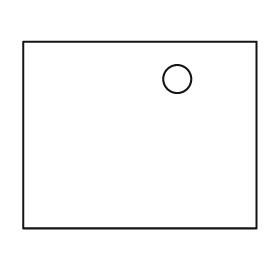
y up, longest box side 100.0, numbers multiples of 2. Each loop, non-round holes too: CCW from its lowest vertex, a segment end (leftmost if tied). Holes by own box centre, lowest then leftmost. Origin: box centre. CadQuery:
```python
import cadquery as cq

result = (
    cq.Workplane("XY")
    .moveTo(-50.0, -40.0)
    .lineTo(50.0, -40.0)
    .lineTo(50.0, 40.0)
    .lineTo(-50.0, 40.0)
    .close()
    .moveTo(16.0, 24.0)
    .circle(6.0)
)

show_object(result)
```